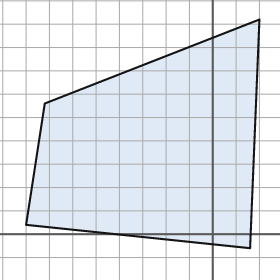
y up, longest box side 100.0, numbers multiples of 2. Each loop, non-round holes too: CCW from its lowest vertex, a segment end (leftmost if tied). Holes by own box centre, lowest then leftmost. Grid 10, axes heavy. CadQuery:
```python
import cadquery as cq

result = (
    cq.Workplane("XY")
    .moveTo(16.0, -6.0)
    .lineTo(20.0, 92.0)
    .lineTo(-72.0, 56.0)
    .lineTo(-80.0, 4.0)
    .close()
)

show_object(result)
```